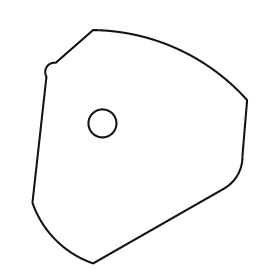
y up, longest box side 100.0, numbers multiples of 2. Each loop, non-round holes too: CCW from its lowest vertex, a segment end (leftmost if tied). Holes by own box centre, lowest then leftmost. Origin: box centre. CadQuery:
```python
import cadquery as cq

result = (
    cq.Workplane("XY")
    .moveTo(-20.0, -50.0)
    .lineTo(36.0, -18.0)
    .threePointArc((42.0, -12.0), (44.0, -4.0))
    .lineTo(46.0, 20.0)
    .threePointArc((16.0, 42.0), (-20.0, 50.0))
    .lineTo(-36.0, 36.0)
    .threePointArc((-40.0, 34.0), (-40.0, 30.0))
    .lineTo(-46.0, -24.0)
    .threePointArc((-36.0, -40.0), (-20.0, -50.0))
    .close()
    .moveTo(-16.0, 10.0)
    .circle(6.0)
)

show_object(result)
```